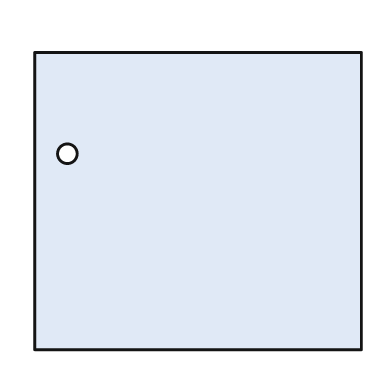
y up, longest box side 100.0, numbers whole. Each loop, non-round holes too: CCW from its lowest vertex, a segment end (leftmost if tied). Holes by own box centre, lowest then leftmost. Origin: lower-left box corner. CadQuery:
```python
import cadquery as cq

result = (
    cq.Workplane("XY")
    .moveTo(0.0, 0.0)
    .lineTo(100.0, 0.0)
    .lineTo(100.0, 91.0)
    .lineTo(0.0, 91.0)
    .close()
    .moveTo(10.0, 60.0)
    .circle(3.0)
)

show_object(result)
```